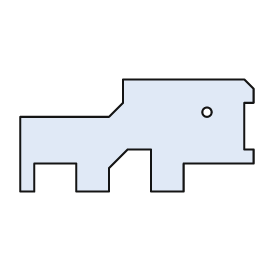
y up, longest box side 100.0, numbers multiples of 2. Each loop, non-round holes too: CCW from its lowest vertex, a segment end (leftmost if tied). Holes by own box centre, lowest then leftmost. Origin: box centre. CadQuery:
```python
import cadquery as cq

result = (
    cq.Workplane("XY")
    .moveTo(-50.0, -24.0)
    .lineTo(-44.0, -24.0)
    .lineTo(-44.0, -12.0)
    .lineTo(-26.0, -12.0)
    .lineTo(-26.0, -24.0)
    .lineTo(-12.0, -24.0)
    .lineTo(-12.0, -14.0)
    .lineTo(-4.0, -6.0)
    .lineTo(6.0, -6.0)
    .lineTo(6.0, -24.0)
    .lineTo(20.0, -24.0)
    .lineTo(20.0, -12.0)
    .lineTo(50.0, -12.0)
    .lineTo(50.0, -6.0)
    .lineTo(46.0, -6.0)
    .lineTo(46.0, 14.0)
    .lineTo(50.0, 14.0)
    .lineTo(50.0, 20.0)
    .lineTo(46.0, 24.0)
    .lineTo(-6.0, 24.0)
    .lineTo(-6.0, 14.0)
    .lineTo(-12.0, 8.0)
    .lineTo(-50.0, 8.0)
    .close()
    .moveTo(30.0, 10.0)
    .circle(2.0)
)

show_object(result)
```